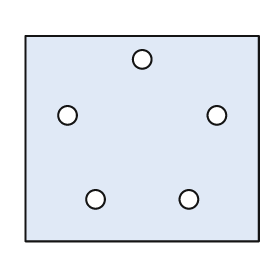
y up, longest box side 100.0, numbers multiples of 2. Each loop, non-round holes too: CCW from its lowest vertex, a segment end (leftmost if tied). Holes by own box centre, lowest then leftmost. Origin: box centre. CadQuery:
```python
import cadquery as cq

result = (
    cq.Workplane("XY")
    .moveTo(-50.0, -44.0)
    .lineTo(50.0, -44.0)
    .lineTo(50.0, 44.0)
    .lineTo(-50.0, 44.0)
    .close()
    .moveTo(-20.0, -26.0)
    .circle(4.0)
    .moveTo(20.0, -26.0)
    .circle(4.0)
    .moveTo(-32.0, 10.0)
    .circle(4.0)
    .moveTo(32.0, 10.0)
    .circle(4.0)
    .moveTo(0.0, 34.0)
    .circle(4.0)
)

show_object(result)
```